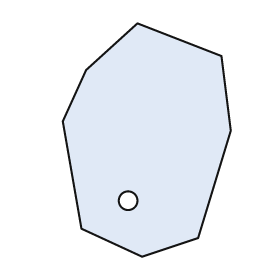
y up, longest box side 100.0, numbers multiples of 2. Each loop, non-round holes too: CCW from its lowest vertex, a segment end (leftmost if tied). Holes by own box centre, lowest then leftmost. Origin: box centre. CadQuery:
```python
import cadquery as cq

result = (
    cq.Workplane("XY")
    .moveTo(-2.0, -50.0)
    .lineTo(22.0, -42.0)
    .lineTo(36.0, 4.0)
    .lineTo(32.0, 36.0)
    .lineTo(-4.0, 50.0)
    .lineTo(-26.0, 30.0)
    .lineTo(-36.0, 8.0)
    .lineTo(-28.0, -38.0)
    .close()
    .moveTo(-8.0, -26.0)
    .circle(4.0)
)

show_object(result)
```